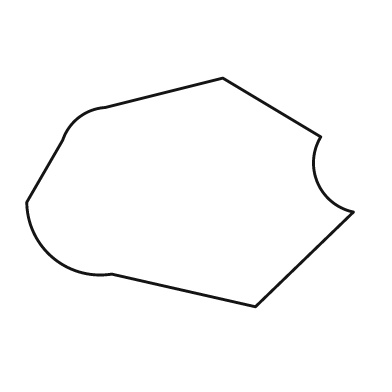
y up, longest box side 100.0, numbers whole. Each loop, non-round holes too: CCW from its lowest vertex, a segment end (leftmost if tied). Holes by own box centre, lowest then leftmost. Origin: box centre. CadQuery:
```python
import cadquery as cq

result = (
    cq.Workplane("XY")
    .moveTo(20.0, -35.0)
    .lineTo(50.0, -6.0)
    .threePointArc((39.0, 3.0), (40.0, 17.0))
    .lineTo(10.0, 35.0)
    .lineTo(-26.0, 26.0)
    .threePointArc((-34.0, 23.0), (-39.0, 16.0))
    .lineTo(-50.0, -3.0)
    .threePointArc((-42.0, -20.0), (-24.0, -25.0))
    .close()
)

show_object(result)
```